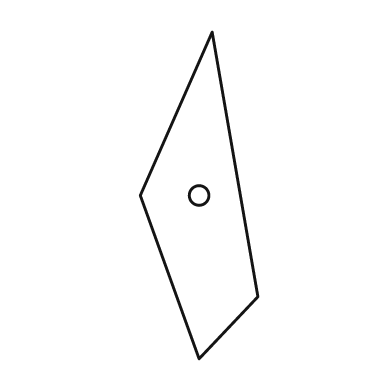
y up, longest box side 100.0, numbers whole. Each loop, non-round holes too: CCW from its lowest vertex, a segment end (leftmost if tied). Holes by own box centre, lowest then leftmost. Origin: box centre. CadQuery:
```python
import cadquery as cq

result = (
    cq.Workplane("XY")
    .moveTo(0.0, -50.0)
    .lineTo(18.0, -31.0)
    .lineTo(4.0, 50.0)
    .lineTo(-18.0, 0.0)
    .close()
    .moveTo(0.0, 0.0)
    .circle(3.0)
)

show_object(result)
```